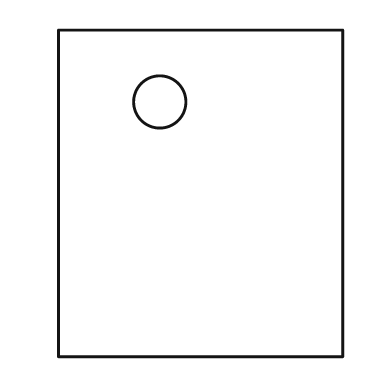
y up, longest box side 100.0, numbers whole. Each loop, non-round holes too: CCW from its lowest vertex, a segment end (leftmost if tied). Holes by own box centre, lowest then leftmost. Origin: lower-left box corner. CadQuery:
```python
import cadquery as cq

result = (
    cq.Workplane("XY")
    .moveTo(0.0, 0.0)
    .lineTo(87.0, 0.0)
    .lineTo(87.0, 100.0)
    .lineTo(0.0, 100.0)
    .close()
    .moveTo(31.0, 78.0)
    .circle(8.0)
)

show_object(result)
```